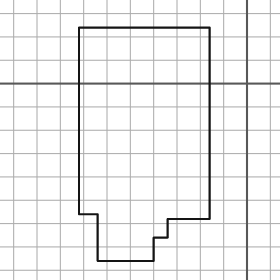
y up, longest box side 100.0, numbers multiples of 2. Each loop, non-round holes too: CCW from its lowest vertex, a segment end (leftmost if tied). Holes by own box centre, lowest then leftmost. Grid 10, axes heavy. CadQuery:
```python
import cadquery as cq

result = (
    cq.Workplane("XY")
    .moveTo(-64.0, -76.0)
    .lineTo(-40.0, -76.0)
    .lineTo(-40.0, -66.0)
    .lineTo(-34.0, -66.0)
    .lineTo(-34.0, -58.0)
    .lineTo(-16.0, -58.0)
    .lineTo(-16.0, 24.0)
    .lineTo(-72.0, 24.0)
    .lineTo(-72.0, -56.0)
    .lineTo(-64.0, -56.0)
    .close()
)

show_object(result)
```